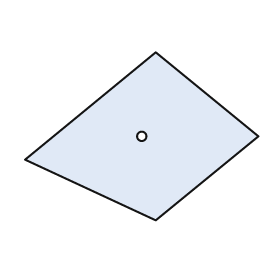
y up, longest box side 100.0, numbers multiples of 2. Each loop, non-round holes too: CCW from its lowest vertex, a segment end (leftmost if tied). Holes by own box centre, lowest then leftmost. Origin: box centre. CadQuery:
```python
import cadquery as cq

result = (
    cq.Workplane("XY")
    .moveTo(6.0, -36.0)
    .lineTo(50.0, 0.0)
    .lineTo(6.0, 36.0)
    .lineTo(-50.0, -10.0)
    .close()
    .moveTo(0.0, 0.0)
    .circle(2.0)
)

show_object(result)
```